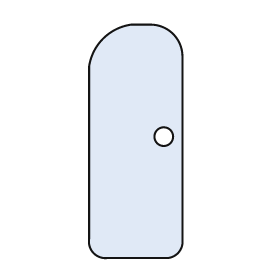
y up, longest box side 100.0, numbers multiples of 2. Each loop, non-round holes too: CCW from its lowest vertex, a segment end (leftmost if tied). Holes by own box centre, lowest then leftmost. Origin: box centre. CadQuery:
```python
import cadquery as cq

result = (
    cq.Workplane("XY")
    .moveTo(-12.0, -50.0)
    .lineTo(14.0, -50.0)
    .threePointArc((18.0, -48.0), (20.0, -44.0))
    .lineTo(20.0, 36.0)
    .threePointArc((16.0, 46.0), (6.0, 50.0))
    .lineTo(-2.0, 50.0)
    .threePointArc((-14.0, 44.0), (-20.0, 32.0))
    .lineTo(-20.0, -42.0)
    .threePointArc((-18.0, -48.0), (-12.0, -50.0))
    .close()
    .moveTo(12.0, 2.0)
    .circle(4.0)
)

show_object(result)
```